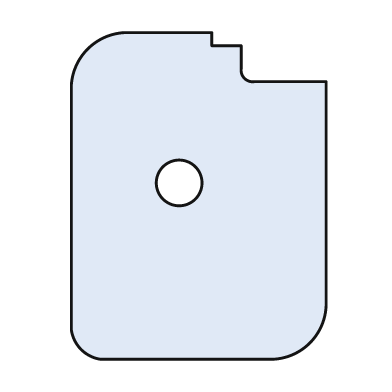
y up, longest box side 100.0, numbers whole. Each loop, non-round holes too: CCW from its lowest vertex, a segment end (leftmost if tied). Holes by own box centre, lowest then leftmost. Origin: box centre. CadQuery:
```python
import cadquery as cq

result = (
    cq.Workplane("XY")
    .moveTo(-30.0, -50.0)
    .lineTo(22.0, -50.0)
    .threePointArc((34.0, -45.0), (39.0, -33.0))
    .lineTo(39.0, 35.0)
    .lineTo(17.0, 35.0)
    .threePointArc((14.0, 36.0), (13.0, 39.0))
    .lineTo(13.0, 46.0)
    .lineTo(4.0, 46.0)
    .lineTo(4.0, 50.0)
    .lineTo(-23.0, 50.0)
    .threePointArc((-34.0, 45.0), (-39.0, 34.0))
    .lineTo(-39.0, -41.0)
    .threePointArc((-36.0, -47.0), (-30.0, -50.0))
    .close()
    .moveTo(-6.0, 4.0)
    .circle(7.0)
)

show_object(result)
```